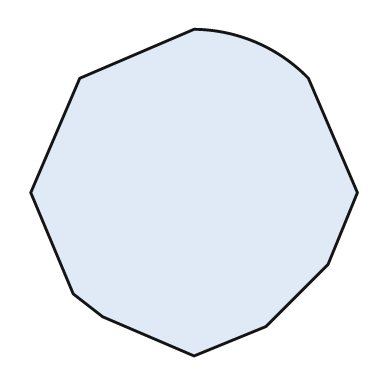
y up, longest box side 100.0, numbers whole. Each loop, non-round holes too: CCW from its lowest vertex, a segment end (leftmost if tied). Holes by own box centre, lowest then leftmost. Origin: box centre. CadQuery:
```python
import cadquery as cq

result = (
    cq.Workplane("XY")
    .moveTo(0.0, -50.0)
    .lineTo(22.0, -41.0)
    .lineTo(41.0, -22.0)
    .lineTo(50.0, 0.0)
    .lineTo(35.0, 35.0)
    .threePointArc((19.0, 46.0), (0.0, 50.0))
    .lineTo(-35.0, 35.0)
    .lineTo(-50.0, 0.0)
    .lineTo(-37.0, -31.0)
    .lineTo(-28.0, -38.0)
    .close()
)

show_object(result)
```